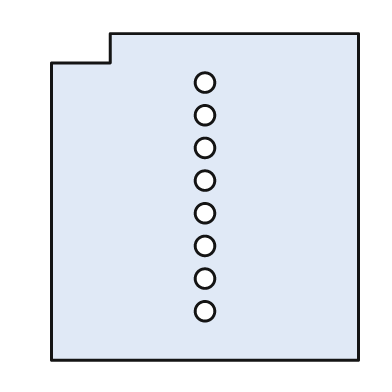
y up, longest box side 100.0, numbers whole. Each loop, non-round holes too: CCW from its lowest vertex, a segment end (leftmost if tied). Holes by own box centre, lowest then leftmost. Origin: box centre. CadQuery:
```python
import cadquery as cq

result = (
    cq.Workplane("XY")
    .moveTo(-47.0, -50.0)
    .lineTo(47.0, -50.0)
    .lineTo(47.0, 50.0)
    .lineTo(-29.0, 50.0)
    .lineTo(-29.0, 41.0)
    .lineTo(-47.0, 41.0)
    .close()
    .moveTo(0.0, -35.0)
    .circle(3.0)
    .moveTo(0.0, -25.0)
    .circle(3.0)
    .moveTo(0.0, -15.0)
    .circle(3.0)
    .moveTo(0.0, -5.0)
    .circle(3.0)
    .moveTo(0.0, 5.0)
    .circle(3.0)
    .moveTo(0.0, 15.0)
    .circle(3.0)
    .moveTo(0.0, 25.0)
    .circle(3.0)
    .moveTo(0.0, 35.0)
    .circle(3.0)
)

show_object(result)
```